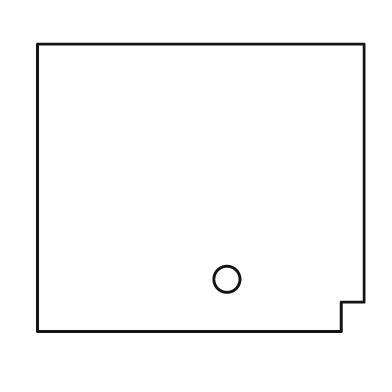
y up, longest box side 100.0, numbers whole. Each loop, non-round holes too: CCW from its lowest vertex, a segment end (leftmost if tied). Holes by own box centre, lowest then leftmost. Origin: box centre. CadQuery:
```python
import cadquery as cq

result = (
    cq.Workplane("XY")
    .moveTo(-50.0, -44.0)
    .lineTo(43.0, -44.0)
    .lineTo(43.0, -35.0)
    .lineTo(50.0, -35.0)
    .lineTo(50.0, 44.0)
    .lineTo(-50.0, 44.0)
    .close()
    .moveTo(8.0, -28.0)
    .circle(4.0)
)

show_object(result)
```